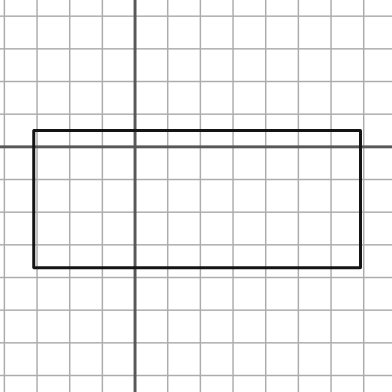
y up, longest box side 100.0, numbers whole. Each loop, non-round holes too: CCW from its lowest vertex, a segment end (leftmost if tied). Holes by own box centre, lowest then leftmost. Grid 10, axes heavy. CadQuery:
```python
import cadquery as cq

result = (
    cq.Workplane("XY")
    .moveTo(-31.0, -37.0)
    .lineTo(69.0, -37.0)
    .lineTo(69.0, 5.0)
    .lineTo(-31.0, 5.0)
    .close()
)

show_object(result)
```